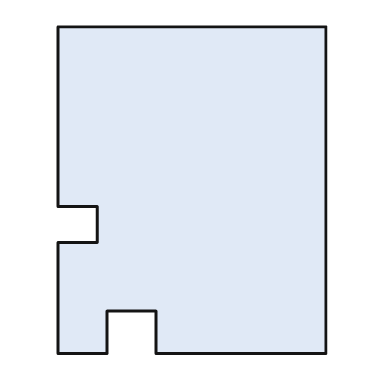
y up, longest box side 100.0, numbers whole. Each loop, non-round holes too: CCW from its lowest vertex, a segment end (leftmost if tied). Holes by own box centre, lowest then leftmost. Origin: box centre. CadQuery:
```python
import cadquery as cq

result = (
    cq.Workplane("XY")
    .moveTo(-41.0, -50.0)
    .lineTo(-26.0, -50.0)
    .lineTo(-26.0, -37.0)
    .lineTo(-11.0, -37.0)
    .lineTo(-11.0, -50.0)
    .lineTo(41.0, -50.0)
    .lineTo(41.0, 50.0)
    .lineTo(-41.0, 50.0)
    .lineTo(-41.0, -5.0)
    .lineTo(-29.0, -5.0)
    .lineTo(-29.0, -16.0)
    .lineTo(-41.0, -16.0)
    .close()
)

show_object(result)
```